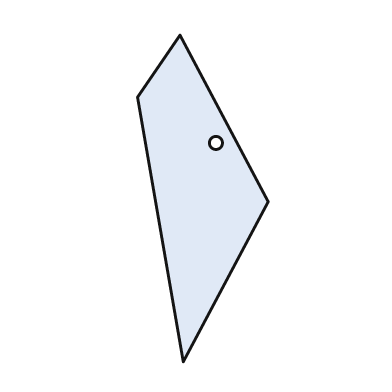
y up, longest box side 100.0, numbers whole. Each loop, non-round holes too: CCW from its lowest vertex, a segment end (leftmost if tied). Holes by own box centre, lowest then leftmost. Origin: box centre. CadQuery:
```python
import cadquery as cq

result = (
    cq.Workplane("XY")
    .moveTo(-6.0, -50.0)
    .lineTo(20.0, -1.0)
    .lineTo(-7.0, 50.0)
    .lineTo(-20.0, 31.0)
    .close()
    .moveTo(4.0, 17.0)
    .circle(2.0)
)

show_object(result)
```